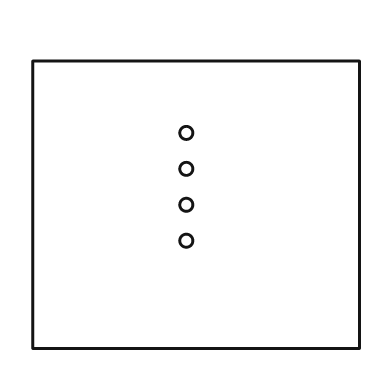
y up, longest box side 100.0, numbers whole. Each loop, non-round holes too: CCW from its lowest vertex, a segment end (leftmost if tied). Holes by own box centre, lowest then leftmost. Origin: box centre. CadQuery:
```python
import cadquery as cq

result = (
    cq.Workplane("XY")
    .moveTo(-50.0, -44.0)
    .lineTo(50.0, -44.0)
    .lineTo(50.0, 44.0)
    .lineTo(-50.0, 44.0)
    .close()
    .moveTo(-3.0, -11.0)
    .circle(2.0)
    .moveTo(-3.0, 0.0)
    .circle(2.0)
    .moveTo(-3.0, 11.0)
    .circle(2.0)
    .moveTo(-3.0, 22.0)
    .circle(2.0)
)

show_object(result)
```